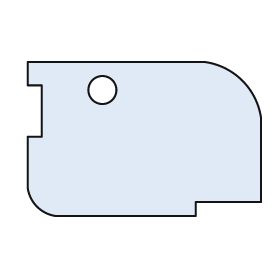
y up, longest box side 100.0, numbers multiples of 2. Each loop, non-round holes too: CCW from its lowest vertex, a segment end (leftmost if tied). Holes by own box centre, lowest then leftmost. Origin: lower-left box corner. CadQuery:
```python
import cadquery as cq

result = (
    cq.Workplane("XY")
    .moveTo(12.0, 0.0)
    .lineTo(72.0, 0.0)
    .lineTo(72.0, 6.0)
    .lineTo(100.0, 6.0)
    .lineTo(100.0, 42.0)
    .threePointArc((92.0, 58.0), (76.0, 66.0))
    .lineTo(0.0, 66.0)
    .lineTo(0.0, 56.0)
    .lineTo(6.0, 56.0)
    .lineTo(6.0, 34.0)
    .lineTo(0.0, 34.0)
    .lineTo(0.0, 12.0)
    .threePointArc((4.0, 4.0), (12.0, 0.0))
    .close()
    .moveTo(32.0, 54.0)
    .circle(6.0)
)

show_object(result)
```